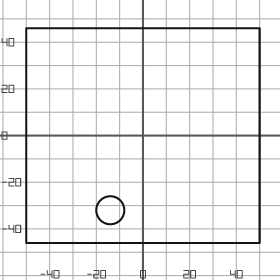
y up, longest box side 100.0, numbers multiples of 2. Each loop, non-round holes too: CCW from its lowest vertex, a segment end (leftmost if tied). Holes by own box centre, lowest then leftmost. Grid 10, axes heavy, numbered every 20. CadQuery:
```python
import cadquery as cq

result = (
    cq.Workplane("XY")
    .moveTo(-50.0, -46.0)
    .lineTo(50.0, -46.0)
    .lineTo(50.0, 46.0)
    .lineTo(-50.0, 46.0)
    .close()
    .moveTo(-14.0, -32.0)
    .circle(6.0)
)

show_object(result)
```